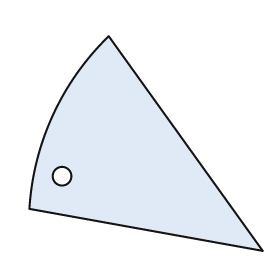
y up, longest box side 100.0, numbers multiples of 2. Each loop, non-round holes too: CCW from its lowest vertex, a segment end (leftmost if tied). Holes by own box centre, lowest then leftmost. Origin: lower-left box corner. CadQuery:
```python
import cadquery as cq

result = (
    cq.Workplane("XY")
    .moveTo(100.0, 0.0)
    .lineTo(34.0, 92.0)
    .threePointArc((10.0, 58.0), (0.0, 18.0))
    .close()
    .moveTo(14.0, 32.0)
    .circle(4.0)
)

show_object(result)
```